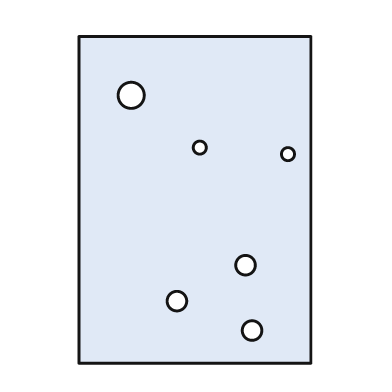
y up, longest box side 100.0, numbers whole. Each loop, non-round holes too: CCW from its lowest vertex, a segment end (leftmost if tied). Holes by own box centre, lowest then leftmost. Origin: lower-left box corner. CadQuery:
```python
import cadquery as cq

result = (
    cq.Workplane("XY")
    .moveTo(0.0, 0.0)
    .lineTo(71.0, 0.0)
    .lineTo(71.0, 100.0)
    .lineTo(0.0, 100.0)
    .close()
    .moveTo(53.0, 10.0)
    .circle(3.0)
    .moveTo(30.0, 19.0)
    .circle(3.0)
    .moveTo(51.0, 30.0)
    .circle(3.0)
    .moveTo(64.0, 64.0)
    .circle(2.0)
    .moveTo(37.0, 66.0)
    .circle(2.0)
    .moveTo(16.0, 82.0)
    .circle(4.0)
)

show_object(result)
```